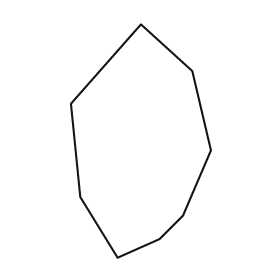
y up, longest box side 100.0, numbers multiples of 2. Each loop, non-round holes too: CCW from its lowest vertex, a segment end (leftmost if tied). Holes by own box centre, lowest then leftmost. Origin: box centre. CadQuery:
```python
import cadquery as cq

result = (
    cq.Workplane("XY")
    .moveTo(-10.0, -50.0)
    .lineTo(8.0, -42.0)
    .lineTo(18.0, -32.0)
    .lineTo(30.0, -4.0)
    .lineTo(22.0, 30.0)
    .lineTo(0.0, 50.0)
    .lineTo(-30.0, 16.0)
    .lineTo(-26.0, -24.0)
    .close()
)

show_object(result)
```